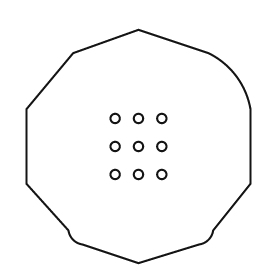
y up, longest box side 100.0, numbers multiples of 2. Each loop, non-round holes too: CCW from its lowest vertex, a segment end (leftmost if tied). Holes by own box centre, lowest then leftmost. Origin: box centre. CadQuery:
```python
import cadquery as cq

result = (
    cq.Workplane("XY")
    .moveTo(0.0, -50.0)
    .lineTo(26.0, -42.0)
    .threePointArc((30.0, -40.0), (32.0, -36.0))
    .lineTo(48.0, -16.0)
    .lineTo(48.0, 16.0)
    .threePointArc((42.0, 30.0), (30.0, 40.0))
    .lineTo(0.0, 50.0)
    .lineTo(-28.0, 40.0)
    .lineTo(-48.0, 16.0)
    .lineTo(-48.0, -16.0)
    .lineTo(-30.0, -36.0)
    .threePointArc((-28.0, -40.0), (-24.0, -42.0))
    .close()
    .moveTo(-10.0, -12.0)
    .circle(2.0)
    .moveTo(0.0, -12.0)
    .circle(2.0)
    .moveTo(10.0, -12.0)
    .circle(2.0)
    .moveTo(-10.0, 0.0)
    .circle(2.0)
    .moveTo(0.0, 0.0)
    .circle(2.0)
    .moveTo(10.0, 0.0)
    .circle(2.0)
    .moveTo(-10.0, 12.0)
    .circle(2.0)
    .moveTo(0.0, 12.0)
    .circle(2.0)
    .moveTo(10.0, 12.0)
    .circle(2.0)
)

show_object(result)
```